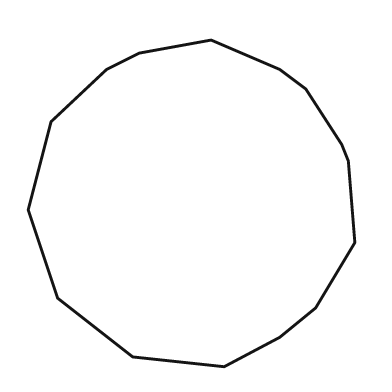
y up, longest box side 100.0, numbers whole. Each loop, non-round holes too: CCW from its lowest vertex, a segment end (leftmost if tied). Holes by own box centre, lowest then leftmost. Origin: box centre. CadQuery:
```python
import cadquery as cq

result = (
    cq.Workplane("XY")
    .moveTo(10.0, -50.0)
    .lineTo(27.0, -41.0)
    .lineTo(38.0, -32.0)
    .lineTo(50.0, -12.0)
    .lineTo(48.0, 13.0)
    .lineTo(46.0, 18.0)
    .lineTo(35.0, 35.0)
    .lineTo(27.0, 41.0)
    .lineTo(6.0, 50.0)
    .lineTo(-16.0, 46.0)
    .lineTo(-26.0, 41.0)
    .lineTo(-43.0, 25.0)
    .lineTo(-50.0, -2.0)
    .lineTo(-41.0, -29.0)
    .lineTo(-18.0, -47.0)
    .close()
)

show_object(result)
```